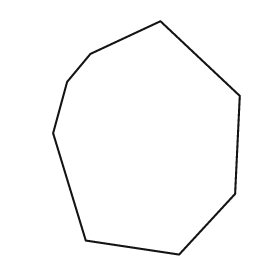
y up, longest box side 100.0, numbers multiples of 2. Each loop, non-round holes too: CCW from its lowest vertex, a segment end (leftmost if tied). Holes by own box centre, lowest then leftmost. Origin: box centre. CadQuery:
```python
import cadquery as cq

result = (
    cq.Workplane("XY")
    .moveTo(14.0, -50.0)
    .lineTo(38.0, -24.0)
    .lineTo(40.0, 18.0)
    .lineTo(6.0, 50.0)
    .lineTo(-24.0, 36.0)
    .lineTo(-34.0, 24.0)
    .lineTo(-40.0, 2.0)
    .lineTo(-26.0, -44.0)
    .close()
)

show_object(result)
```